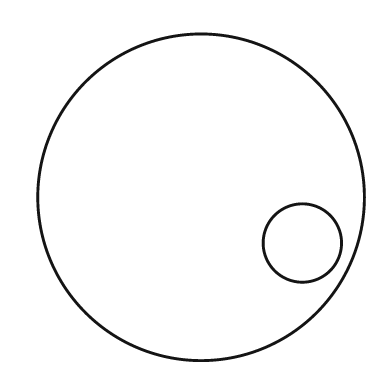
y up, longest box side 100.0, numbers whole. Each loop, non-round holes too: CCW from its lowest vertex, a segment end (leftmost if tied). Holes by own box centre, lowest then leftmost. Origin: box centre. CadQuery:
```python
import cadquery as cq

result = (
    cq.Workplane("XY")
    .moveTo(0.0, 0.0)
    .circle(50.0)
    .moveTo(31.0, -14.0)
    .circle(12.0)
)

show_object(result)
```